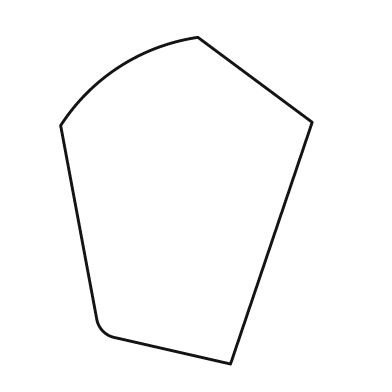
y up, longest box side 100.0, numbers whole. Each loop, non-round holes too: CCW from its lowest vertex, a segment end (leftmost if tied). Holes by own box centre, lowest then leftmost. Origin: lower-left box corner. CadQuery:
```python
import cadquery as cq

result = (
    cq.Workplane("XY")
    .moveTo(52.0, 0.0)
    .lineTo(77.0, 74.0)
    .lineTo(42.0, 100.0)
    .threePointArc((18.0, 91.0), (0.0, 73.0))
    .lineTo(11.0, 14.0)
    .threePointArc((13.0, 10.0), (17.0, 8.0))
    .close()
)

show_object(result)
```